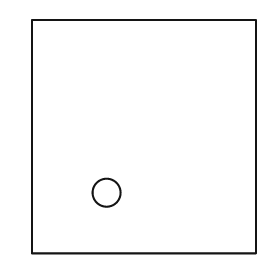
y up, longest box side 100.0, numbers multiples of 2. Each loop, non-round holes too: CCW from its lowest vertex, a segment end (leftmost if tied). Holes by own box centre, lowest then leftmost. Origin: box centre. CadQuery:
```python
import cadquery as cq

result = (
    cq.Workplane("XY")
    .moveTo(-48.0, -50.0)
    .lineTo(48.0, -50.0)
    .lineTo(48.0, 50.0)
    .lineTo(-48.0, 50.0)
    .close()
    .moveTo(-16.0, -24.0)
    .circle(6.0)
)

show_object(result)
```